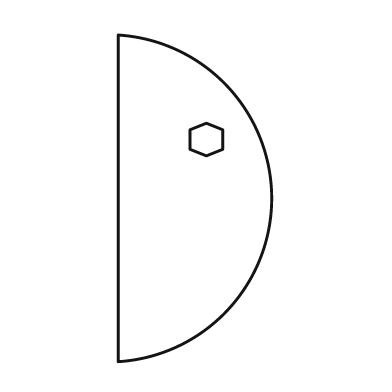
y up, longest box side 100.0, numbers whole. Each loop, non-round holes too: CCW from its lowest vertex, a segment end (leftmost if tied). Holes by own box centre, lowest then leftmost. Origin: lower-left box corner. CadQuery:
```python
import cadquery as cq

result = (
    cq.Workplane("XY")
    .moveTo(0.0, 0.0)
    .threePointArc((47.0, 50.0), (0.0, 100.0))
    .close()
    .moveTo(27.0, 63.0)
    .lineTo(32.0, 65.0)
    .lineTo(32.0, 71.0)
    .lineTo(27.0, 73.0)
    .lineTo(22.0, 71.0)
    .lineTo(22.0, 65.0)
    .close()
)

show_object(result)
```